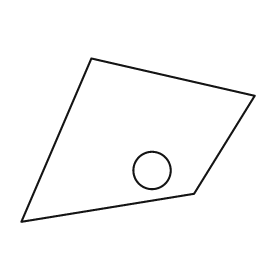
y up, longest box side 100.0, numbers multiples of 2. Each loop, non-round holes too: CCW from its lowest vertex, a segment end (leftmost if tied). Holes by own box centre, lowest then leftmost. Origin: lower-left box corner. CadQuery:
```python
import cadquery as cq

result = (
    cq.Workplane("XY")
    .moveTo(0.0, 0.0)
    .lineTo(74.0, 12.0)
    .lineTo(100.0, 54.0)
    .lineTo(30.0, 70.0)
    .close()
    .moveTo(56.0, 22.0)
    .circle(8.0)
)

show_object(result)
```